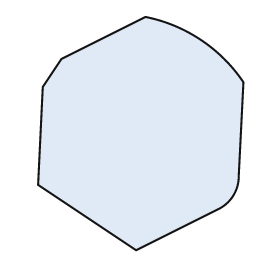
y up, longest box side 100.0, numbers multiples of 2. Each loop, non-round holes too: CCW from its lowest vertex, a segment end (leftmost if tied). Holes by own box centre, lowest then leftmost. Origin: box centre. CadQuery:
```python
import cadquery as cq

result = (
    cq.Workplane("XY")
    .moveTo(-2.0, -50.0)
    .lineTo(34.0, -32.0)
    .threePointArc((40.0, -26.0), (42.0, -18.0))
    .lineTo(44.0, 22.0)
    .threePointArc((26.0, 40.0), (2.0, 50.0))
    .lineTo(-34.0, 32.0)
    .lineTo(-42.0, 20.0)
    .lineTo(-44.0, -22.0)
    .close()
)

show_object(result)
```